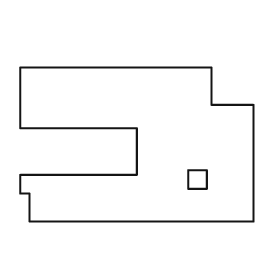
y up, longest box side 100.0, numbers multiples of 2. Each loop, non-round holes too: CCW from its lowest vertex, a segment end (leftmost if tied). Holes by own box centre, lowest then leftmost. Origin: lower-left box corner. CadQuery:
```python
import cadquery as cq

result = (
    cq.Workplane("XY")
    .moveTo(4.0, 0.0)
    .lineTo(100.0, 0.0)
    .lineTo(100.0, 50.0)
    .lineTo(82.0, 50.0)
    .lineTo(82.0, 66.0)
    .lineTo(0.0, 66.0)
    .lineTo(0.0, 40.0)
    .lineTo(50.0, 40.0)
    .lineTo(50.0, 20.0)
    .lineTo(0.0, 20.0)
    .lineTo(0.0, 12.0)
    .lineTo(4.0, 12.0)
    .close()
    .moveTo(72.0, 14.0)
    .lineTo(80.0, 14.0)
    .lineTo(80.0, 22.0)
    .lineTo(72.0, 22.0)
    .close()
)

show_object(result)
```